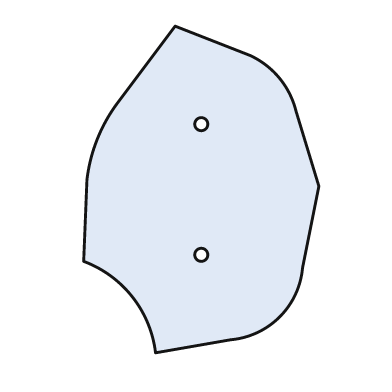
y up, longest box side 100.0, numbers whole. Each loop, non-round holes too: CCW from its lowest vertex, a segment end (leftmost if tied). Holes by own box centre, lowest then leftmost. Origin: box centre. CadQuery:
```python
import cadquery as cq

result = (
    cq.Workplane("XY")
    .moveTo(-14.0, -50.0)
    .lineTo(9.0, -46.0)
    .threePointArc((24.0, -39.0), (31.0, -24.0))
    .lineTo(36.0, 1.0)
    .lineTo(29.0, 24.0)
    .threePointArc((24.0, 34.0), (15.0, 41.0))
    .lineTo(-8.0, 50.0)
    .lineTo(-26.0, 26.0)
    .threePointArc((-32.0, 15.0), (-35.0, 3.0))
    .lineTo(-36.0, -22.0)
    .threePointArc((-21.0, -33.0), (-14.0, -50.0))
    .close()
    .moveTo(0.0, -20.0)
    .circle(2.0)
    .moveTo(0.0, 20.0)
    .circle(2.0)
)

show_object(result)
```